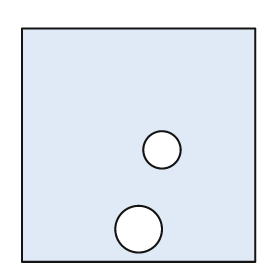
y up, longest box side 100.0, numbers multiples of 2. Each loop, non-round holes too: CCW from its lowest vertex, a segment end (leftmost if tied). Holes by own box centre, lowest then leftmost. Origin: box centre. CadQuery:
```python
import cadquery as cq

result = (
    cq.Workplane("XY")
    .moveTo(-50.0, -50.0)
    .lineTo(50.0, -50.0)
    .lineTo(50.0, 50.0)
    .lineTo(-50.0, 50.0)
    .close()
    .moveTo(0.0, -36.0)
    .circle(10.0)
    .moveTo(10.0, -2.0)
    .circle(8.0)
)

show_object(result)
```